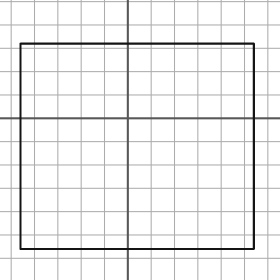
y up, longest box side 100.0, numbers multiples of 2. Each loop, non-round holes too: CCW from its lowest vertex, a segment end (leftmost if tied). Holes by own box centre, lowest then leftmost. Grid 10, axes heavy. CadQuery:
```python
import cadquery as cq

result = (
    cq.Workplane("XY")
    .moveTo(-46.0, -56.0)
    .lineTo(54.0, -56.0)
    .lineTo(54.0, 32.0)
    .lineTo(-46.0, 32.0)
    .close()
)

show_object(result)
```